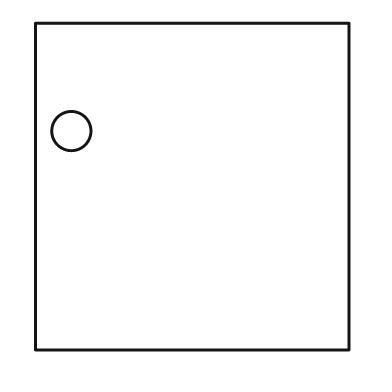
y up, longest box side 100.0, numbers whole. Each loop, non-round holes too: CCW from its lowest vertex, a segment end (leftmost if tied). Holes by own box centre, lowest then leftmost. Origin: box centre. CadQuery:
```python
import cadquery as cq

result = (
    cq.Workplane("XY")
    .moveTo(-48.0, -50.0)
    .lineTo(48.0, -50.0)
    .lineTo(48.0, 50.0)
    .lineTo(-48.0, 50.0)
    .close()
    .moveTo(-37.0, 17.0)
    .circle(6.0)
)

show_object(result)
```